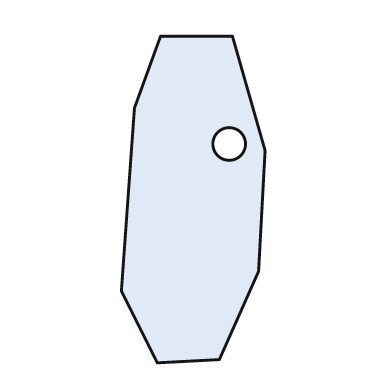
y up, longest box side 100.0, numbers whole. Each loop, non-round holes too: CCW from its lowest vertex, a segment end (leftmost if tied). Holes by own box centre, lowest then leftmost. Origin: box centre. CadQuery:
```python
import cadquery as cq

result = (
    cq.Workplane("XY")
    .moveTo(-11.0, -50.0)
    .lineTo(8.0, -49.0)
    .lineTo(20.0, -22.0)
    .lineTo(22.0, 15.0)
    .lineTo(12.0, 50.0)
    .lineTo(-10.0, 50.0)
    .lineTo(-18.0, 28.0)
    .lineTo(-22.0, -28.0)
    .close()
    .moveTo(11.0, 17.0)
    .circle(5.0)
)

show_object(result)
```